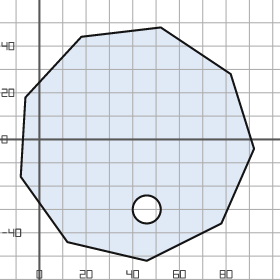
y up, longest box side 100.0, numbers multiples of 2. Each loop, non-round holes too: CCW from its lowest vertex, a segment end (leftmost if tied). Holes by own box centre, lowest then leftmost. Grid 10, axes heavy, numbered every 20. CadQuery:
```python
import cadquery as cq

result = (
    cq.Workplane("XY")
    .moveTo(46.0, -52.0)
    .lineTo(78.0, -36.0)
    .lineTo(92.0, -4.0)
    .lineTo(82.0, 28.0)
    .lineTo(52.0, 48.0)
    .lineTo(18.0, 44.0)
    .lineTo(-6.0, 18.0)
    .lineTo(-8.0, -16.0)
    .lineTo(12.0, -44.0)
    .close()
    .moveTo(46.0, -30.0)
    .circle(6.0)
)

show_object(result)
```